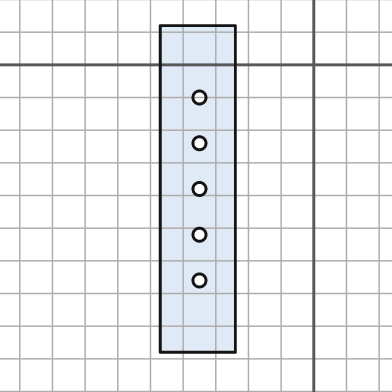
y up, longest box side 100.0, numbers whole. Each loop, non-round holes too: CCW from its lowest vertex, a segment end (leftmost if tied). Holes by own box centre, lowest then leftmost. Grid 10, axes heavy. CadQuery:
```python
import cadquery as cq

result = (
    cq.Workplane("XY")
    .moveTo(-47.0, -88.0)
    .lineTo(-24.0, -88.0)
    .lineTo(-24.0, 12.0)
    .lineTo(-47.0, 12.0)
    .close()
    .moveTo(-35.0, -66.0)
    .circle(2.0)
    .moveTo(-35.0, -52.0)
    .circle(2.0)
    .moveTo(-35.0, -38.0)
    .circle(2.0)
    .moveTo(-35.0, -24.0)
    .circle(2.0)
    .moveTo(-35.0, -10.0)
    .circle(2.0)
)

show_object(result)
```